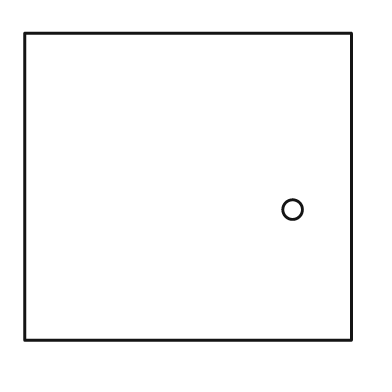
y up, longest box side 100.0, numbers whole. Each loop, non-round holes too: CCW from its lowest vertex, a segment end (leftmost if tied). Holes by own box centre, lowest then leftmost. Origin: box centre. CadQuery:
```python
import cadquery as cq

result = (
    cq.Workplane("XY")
    .moveTo(-50.0, -47.0)
    .lineTo(50.0, -47.0)
    .lineTo(50.0, 47.0)
    .lineTo(-50.0, 47.0)
    .close()
    .moveTo(32.0, -7.0)
    .circle(3.0)
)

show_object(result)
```